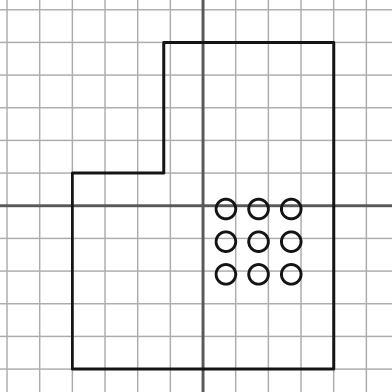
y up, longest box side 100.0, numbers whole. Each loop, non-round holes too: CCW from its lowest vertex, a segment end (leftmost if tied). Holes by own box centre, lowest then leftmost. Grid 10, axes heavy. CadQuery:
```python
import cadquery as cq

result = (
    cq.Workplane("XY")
    .moveTo(-40.0, -50.0)
    .lineTo(40.0, -50.0)
    .lineTo(40.0, 50.0)
    .lineTo(-12.0, 50.0)
    .lineTo(-12.0, 10.0)
    .lineTo(-40.0, 10.0)
    .close()
    .moveTo(7.0, -21.0)
    .circle(3.0)
    .moveTo(17.0, -21.0)
    .circle(3.0)
    .moveTo(27.0, -21.0)
    .circle(3.0)
    .moveTo(7.0, -11.0)
    .circle(3.0)
    .moveTo(17.0, -11.0)
    .circle(3.0)
    .moveTo(27.0, -11.0)
    .circle(3.0)
    .moveTo(7.0, -1.0)
    .circle(3.0)
    .moveTo(17.0, -1.0)
    .circle(3.0)
    .moveTo(27.0, -1.0)
    .circle(3.0)
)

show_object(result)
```